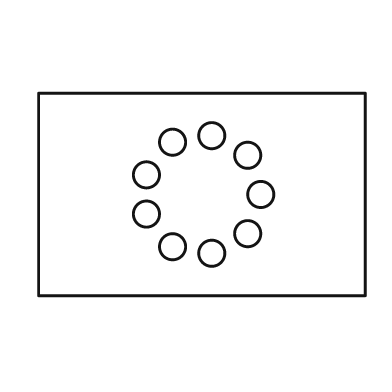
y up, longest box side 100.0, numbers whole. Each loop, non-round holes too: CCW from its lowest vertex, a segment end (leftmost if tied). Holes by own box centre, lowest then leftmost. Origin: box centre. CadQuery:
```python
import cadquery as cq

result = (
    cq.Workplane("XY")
    .moveTo(-50.0, -31.0)
    .lineTo(50.0, -31.0)
    .lineTo(50.0, 31.0)
    .lineTo(-50.0, 31.0)
    .close()
    .moveTo(3.0, -18.0)
    .circle(4.0)
    .moveTo(-9.0, -16.0)
    .circle(4.0)
    .moveTo(14.0, -12.0)
    .circle(4.0)
    .moveTo(-17.0, -6.0)
    .circle(4.0)
    .moveTo(18.0, 0.0)
    .circle(4.0)
    .moveTo(-17.0, 6.0)
    .circle(4.0)
    .moveTo(14.0, 12.0)
    .circle(4.0)
    .moveTo(-9.0, 16.0)
    .circle(4.0)
    .moveTo(3.0, 18.0)
    .circle(4.0)
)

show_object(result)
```